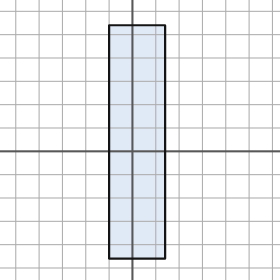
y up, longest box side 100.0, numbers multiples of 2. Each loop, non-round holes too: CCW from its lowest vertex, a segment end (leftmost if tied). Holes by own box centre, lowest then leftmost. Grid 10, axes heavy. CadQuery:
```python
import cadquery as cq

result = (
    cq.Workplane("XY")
    .moveTo(-10.0, -46.0)
    .lineTo(14.0, -46.0)
    .lineTo(14.0, 54.0)
    .lineTo(-10.0, 54.0)
    .close()
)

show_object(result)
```